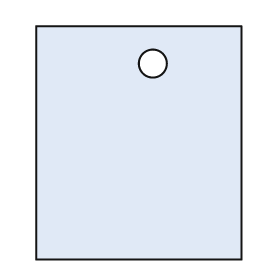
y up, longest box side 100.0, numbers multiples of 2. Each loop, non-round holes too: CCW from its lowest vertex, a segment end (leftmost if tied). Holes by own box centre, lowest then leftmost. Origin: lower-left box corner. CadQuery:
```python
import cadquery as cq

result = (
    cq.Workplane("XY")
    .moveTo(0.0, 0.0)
    .lineTo(88.0, 0.0)
    .lineTo(88.0, 100.0)
    .lineTo(0.0, 100.0)
    .close()
    .moveTo(50.0, 84.0)
    .circle(6.0)
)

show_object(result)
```